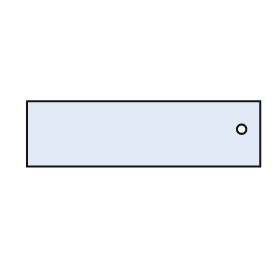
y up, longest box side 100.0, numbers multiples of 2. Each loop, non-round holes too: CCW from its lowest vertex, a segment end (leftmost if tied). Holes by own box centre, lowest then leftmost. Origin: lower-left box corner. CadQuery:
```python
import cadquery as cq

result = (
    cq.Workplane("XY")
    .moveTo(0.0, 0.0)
    .lineTo(100.0, 0.0)
    .lineTo(100.0, 28.0)
    .lineTo(0.0, 28.0)
    .close()
    .moveTo(92.0, 16.0)
    .circle(2.0)
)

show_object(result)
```